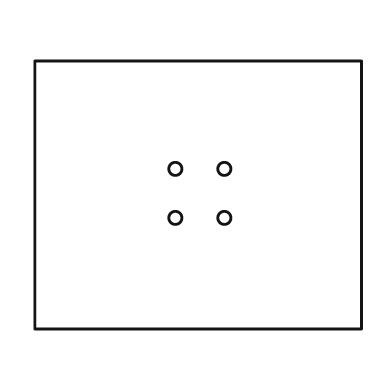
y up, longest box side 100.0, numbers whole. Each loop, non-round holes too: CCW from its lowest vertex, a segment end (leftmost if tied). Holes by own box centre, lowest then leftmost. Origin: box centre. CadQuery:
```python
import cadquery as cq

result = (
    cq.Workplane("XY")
    .moveTo(-50.0, -41.0)
    .lineTo(50.0, -41.0)
    .lineTo(50.0, 41.0)
    .lineTo(-50.0, 41.0)
    .close()
    .moveTo(-7.0, -7.0)
    .circle(2.0)
    .moveTo(8.0, -7.0)
    .circle(2.0)
    .moveTo(-7.0, 8.0)
    .circle(2.0)
    .moveTo(8.0, 8.0)
    .circle(2.0)
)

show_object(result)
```